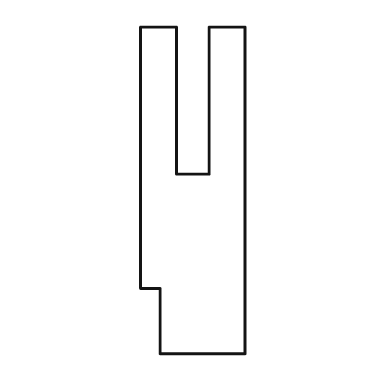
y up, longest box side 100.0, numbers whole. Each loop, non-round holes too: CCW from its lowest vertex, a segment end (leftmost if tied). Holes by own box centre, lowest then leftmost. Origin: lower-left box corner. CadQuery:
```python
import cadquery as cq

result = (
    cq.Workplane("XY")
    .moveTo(6.0, 0.0)
    .lineTo(32.0, 0.0)
    .lineTo(32.0, 100.0)
    .lineTo(21.0, 100.0)
    .lineTo(21.0, 55.0)
    .lineTo(11.0, 55.0)
    .lineTo(11.0, 100.0)
    .lineTo(0.0, 100.0)
    .lineTo(0.0, 20.0)
    .lineTo(6.0, 20.0)
    .close()
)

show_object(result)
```